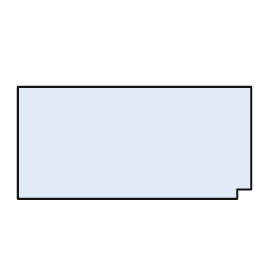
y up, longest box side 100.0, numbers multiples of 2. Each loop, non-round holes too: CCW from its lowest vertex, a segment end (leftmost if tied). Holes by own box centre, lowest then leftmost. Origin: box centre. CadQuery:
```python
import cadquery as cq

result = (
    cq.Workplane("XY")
    .moveTo(-50.0, -24.0)
    .lineTo(44.0, -24.0)
    .lineTo(44.0, -20.0)
    .lineTo(50.0, -20.0)
    .lineTo(50.0, 24.0)
    .lineTo(-50.0, 24.0)
    .close()
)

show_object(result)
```